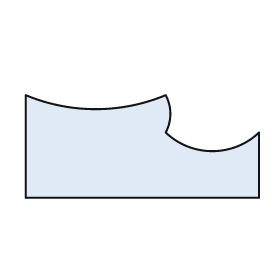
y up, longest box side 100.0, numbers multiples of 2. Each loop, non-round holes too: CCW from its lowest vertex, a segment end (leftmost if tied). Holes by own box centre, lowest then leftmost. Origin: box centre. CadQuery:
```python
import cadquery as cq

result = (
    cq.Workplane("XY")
    .moveTo(-50.0, -22.0)
    .lineTo(50.0, -22.0)
    .lineTo(50.0, 6.0)
    .threePointArc((30.0, -2.0), (10.0, 6.0))
    .threePointArc((12.0, 14.0), (10.0, 22.0))
    .threePointArc((-20.0, 16.0), (-50.0, 22.0))
    .close()
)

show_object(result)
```